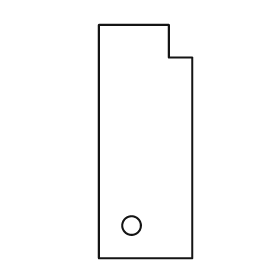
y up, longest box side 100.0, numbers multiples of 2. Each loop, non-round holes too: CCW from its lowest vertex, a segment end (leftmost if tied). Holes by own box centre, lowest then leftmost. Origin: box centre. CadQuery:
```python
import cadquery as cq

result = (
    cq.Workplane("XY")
    .moveTo(-20.0, -50.0)
    .lineTo(20.0, -50.0)
    .lineTo(20.0, 36.0)
    .lineTo(10.0, 36.0)
    .lineTo(10.0, 50.0)
    .lineTo(-20.0, 50.0)
    .close()
    .moveTo(-6.0, -36.0)
    .circle(4.0)
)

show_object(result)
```